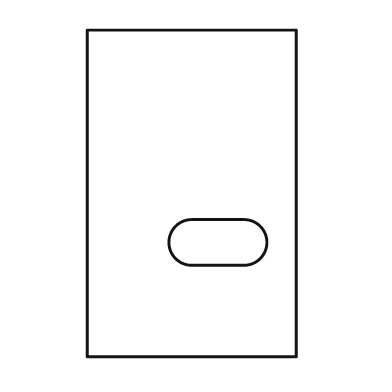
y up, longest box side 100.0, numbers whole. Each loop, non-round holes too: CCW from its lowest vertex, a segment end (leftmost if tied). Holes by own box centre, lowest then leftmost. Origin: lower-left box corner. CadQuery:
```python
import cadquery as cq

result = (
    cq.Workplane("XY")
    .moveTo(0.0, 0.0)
    .lineTo(64.0, 0.0)
    .lineTo(64.0, 100.0)
    .lineTo(0.0, 100.0)
    .close()
    .moveTo(32.0, 28.0)
    .lineTo(48.0, 28.0)
    .threePointArc((55.0, 35.0), (48.0, 42.0))
    .lineTo(32.0, 42.0)
    .threePointArc((25.0, 35.0), (32.0, 28.0))
    .close()
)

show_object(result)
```